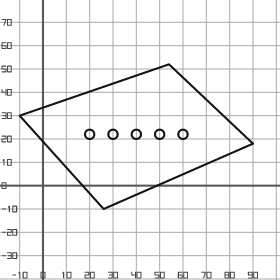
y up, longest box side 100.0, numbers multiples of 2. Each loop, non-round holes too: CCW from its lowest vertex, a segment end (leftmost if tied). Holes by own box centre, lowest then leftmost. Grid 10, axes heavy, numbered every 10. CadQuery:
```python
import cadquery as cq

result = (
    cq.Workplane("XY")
    .moveTo(26.0, -10.0)
    .lineTo(90.0, 18.0)
    .lineTo(54.0, 52.0)
    .lineTo(-10.0, 30.0)
    .close()
    .moveTo(20.0, 22.0)
    .circle(2.0)
    .moveTo(30.0, 22.0)
    .circle(2.0)
    .moveTo(40.0, 22.0)
    .circle(2.0)
    .moveTo(50.0, 22.0)
    .circle(2.0)
    .moveTo(60.0, 22.0)
    .circle(2.0)
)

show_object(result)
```